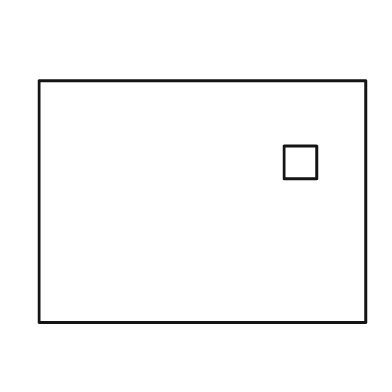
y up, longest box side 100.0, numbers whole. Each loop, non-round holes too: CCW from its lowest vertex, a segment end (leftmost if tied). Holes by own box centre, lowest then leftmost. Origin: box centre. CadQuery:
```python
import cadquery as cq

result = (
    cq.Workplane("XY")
    .moveTo(-50.0, -37.0)
    .lineTo(50.0, -37.0)
    .lineTo(50.0, 37.0)
    .lineTo(-50.0, 37.0)
    .close()
    .moveTo(25.0, 7.0)
    .lineTo(35.0, 7.0)
    .lineTo(35.0, 17.0)
    .lineTo(25.0, 17.0)
    .close()
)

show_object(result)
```